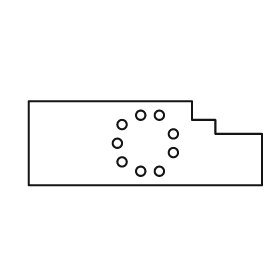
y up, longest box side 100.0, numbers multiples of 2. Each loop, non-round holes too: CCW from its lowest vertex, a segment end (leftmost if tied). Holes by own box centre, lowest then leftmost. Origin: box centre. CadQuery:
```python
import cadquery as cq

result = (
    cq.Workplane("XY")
    .moveTo(-50.0, -18.0)
    .lineTo(50.0, -18.0)
    .lineTo(50.0, 4.0)
    .lineTo(30.0, 4.0)
    .lineTo(30.0, 10.0)
    .lineTo(20.0, 10.0)
    .lineTo(20.0, 18.0)
    .lineTo(-50.0, 18.0)
    .close()
    .moveTo(-2.0, -12.0)
    .circle(2.0)
    .moveTo(6.0, -12.0)
    .circle(2.0)
    .moveTo(-10.0, -8.0)
    .circle(2.0)
    .moveTo(12.0, -4.0)
    .circle(2.0)
    .moveTo(-12.0, 0.0)
    .circle(2.0)
    .moveTo(12.0, 4.0)
    .circle(2.0)
    .moveTo(-10.0, 8.0)
    .circle(2.0)
    .moveTo(-2.0, 12.0)
    .circle(2.0)
    .moveTo(6.0, 12.0)
    .circle(2.0)
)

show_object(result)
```